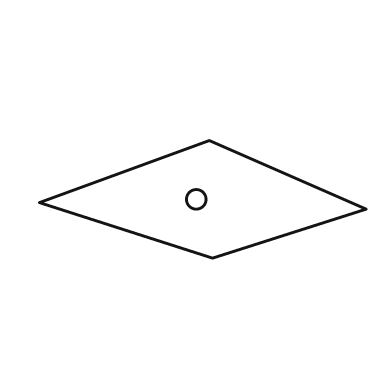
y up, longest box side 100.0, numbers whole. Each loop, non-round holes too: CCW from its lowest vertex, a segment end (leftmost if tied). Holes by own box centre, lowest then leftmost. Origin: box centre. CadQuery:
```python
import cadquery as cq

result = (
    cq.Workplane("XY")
    .moveTo(3.0, -18.0)
    .lineTo(50.0, -3.0)
    .lineTo(2.0, 18.0)
    .lineTo(-50.0, -1.0)
    .close()
    .moveTo(-2.0, 0.0)
    .circle(3.0)
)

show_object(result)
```